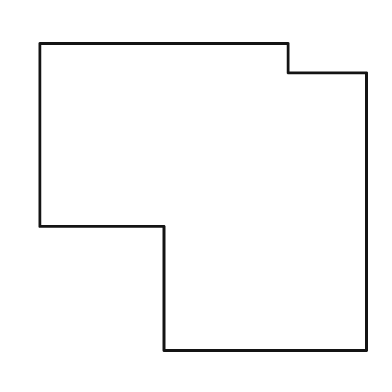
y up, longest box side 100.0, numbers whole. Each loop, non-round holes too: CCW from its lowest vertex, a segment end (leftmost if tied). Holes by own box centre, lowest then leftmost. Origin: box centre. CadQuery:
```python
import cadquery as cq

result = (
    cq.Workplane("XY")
    .moveTo(-12.0, -47.0)
    .lineTo(50.0, -47.0)
    .lineTo(50.0, 38.0)
    .lineTo(26.0, 38.0)
    .lineTo(26.0, 47.0)
    .lineTo(-50.0, 47.0)
    .lineTo(-50.0, -9.0)
    .lineTo(-12.0, -9.0)
    .close()
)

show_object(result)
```